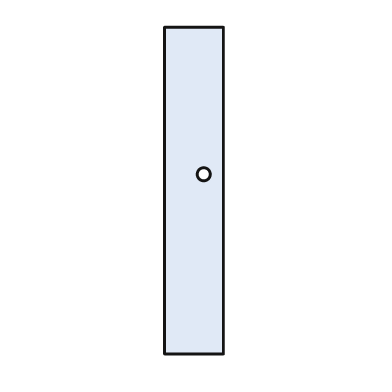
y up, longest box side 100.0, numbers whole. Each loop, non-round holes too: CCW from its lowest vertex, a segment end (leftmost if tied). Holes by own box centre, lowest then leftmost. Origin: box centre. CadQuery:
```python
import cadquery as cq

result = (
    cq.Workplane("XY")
    .moveTo(-9.0, -50.0)
    .lineTo(9.0, -50.0)
    .lineTo(9.0, 50.0)
    .lineTo(-9.0, 50.0)
    .close()
    .moveTo(3.0, 5.0)
    .circle(2.0)
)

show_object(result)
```